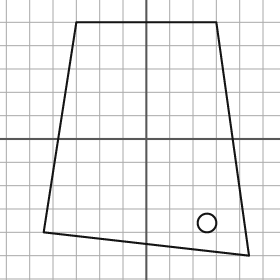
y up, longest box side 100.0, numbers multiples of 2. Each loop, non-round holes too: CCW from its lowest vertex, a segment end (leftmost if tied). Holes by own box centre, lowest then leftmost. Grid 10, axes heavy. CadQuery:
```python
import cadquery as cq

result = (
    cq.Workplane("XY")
    .moveTo(44.0, -50.0)
    .lineTo(30.0, 50.0)
    .lineTo(-30.0, 50.0)
    .lineTo(-44.0, -40.0)
    .close()
    .moveTo(26.0, -36.0)
    .circle(4.0)
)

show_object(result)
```